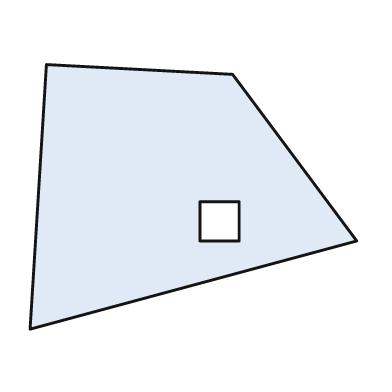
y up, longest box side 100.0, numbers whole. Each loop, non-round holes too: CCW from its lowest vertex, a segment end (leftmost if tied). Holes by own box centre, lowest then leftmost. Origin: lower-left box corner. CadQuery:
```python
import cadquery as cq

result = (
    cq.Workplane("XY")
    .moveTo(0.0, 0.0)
    .lineTo(100.0, 27.0)
    .lineTo(62.0, 78.0)
    .lineTo(5.0, 81.0)
    .close()
    .moveTo(52.0, 27.0)
    .lineTo(64.0, 27.0)
    .lineTo(64.0, 39.0)
    .lineTo(52.0, 39.0)
    .close()
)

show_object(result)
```